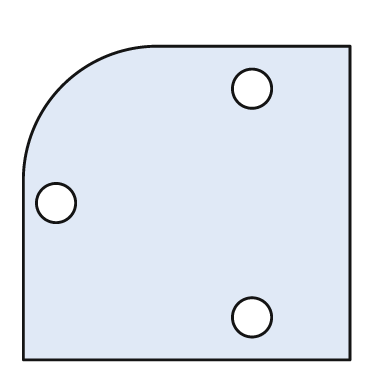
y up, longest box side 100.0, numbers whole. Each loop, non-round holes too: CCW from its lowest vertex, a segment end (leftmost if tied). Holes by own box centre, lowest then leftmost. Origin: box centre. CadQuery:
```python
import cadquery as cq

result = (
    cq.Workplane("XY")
    .moveTo(-50.0, -48.0)
    .lineTo(50.0, -48.0)
    .lineTo(50.0, 48.0)
    .lineTo(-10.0, 48.0)
    .threePointArc((-38.0, 36.0), (-50.0, 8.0))
    .close()
    .moveTo(20.0, -35.0)
    .circle(6.0)
    .moveTo(-40.0, 0.0)
    .circle(6.0)
    .moveTo(20.0, 35.0)
    .circle(6.0)
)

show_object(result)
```